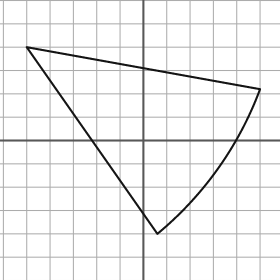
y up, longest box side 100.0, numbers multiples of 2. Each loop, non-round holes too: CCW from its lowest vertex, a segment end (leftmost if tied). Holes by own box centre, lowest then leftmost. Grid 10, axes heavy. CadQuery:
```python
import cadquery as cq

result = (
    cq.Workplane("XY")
    .moveTo(6.0, -40.0)
    .threePointArc((32.0, -12.0), (50.0, 22.0))
    .lineTo(-50.0, 40.0)
    .close()
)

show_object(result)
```